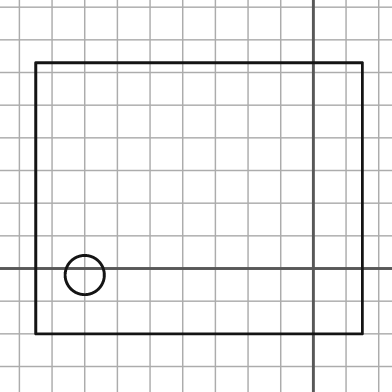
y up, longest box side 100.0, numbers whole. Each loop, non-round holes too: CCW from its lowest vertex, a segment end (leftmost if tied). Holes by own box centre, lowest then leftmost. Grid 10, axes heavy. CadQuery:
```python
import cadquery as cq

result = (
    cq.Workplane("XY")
    .moveTo(-85.0, -20.0)
    .lineTo(15.0, -20.0)
    .lineTo(15.0, 63.0)
    .lineTo(-85.0, 63.0)
    .close()
    .moveTo(-70.0, -2.0)
    .circle(6.0)
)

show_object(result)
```